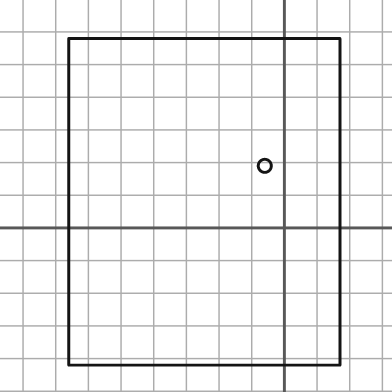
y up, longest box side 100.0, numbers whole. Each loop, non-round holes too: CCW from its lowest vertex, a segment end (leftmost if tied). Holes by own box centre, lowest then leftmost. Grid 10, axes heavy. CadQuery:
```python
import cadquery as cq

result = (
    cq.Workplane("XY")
    .moveTo(-66.0, -42.0)
    .lineTo(17.0, -42.0)
    .lineTo(17.0, 58.0)
    .lineTo(-66.0, 58.0)
    .close()
    .moveTo(-6.0, 19.0)
    .circle(2.0)
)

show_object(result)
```